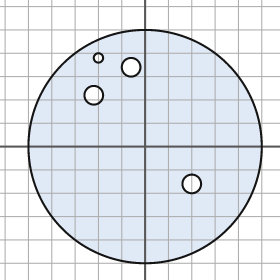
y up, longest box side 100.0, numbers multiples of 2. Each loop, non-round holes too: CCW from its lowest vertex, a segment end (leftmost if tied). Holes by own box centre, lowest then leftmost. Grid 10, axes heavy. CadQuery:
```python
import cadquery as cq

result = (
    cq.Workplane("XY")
    .moveTo(0.0, 0.0)
    .circle(50.0)
    .moveTo(20.0, -16.0)
    .circle(4.0)
    .moveTo(-22.0, 22.0)
    .circle(4.0)
    .moveTo(-6.0, 34.0)
    .circle(4.0)
    .moveTo(-20.0, 38.0)
    .circle(2.0)
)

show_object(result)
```